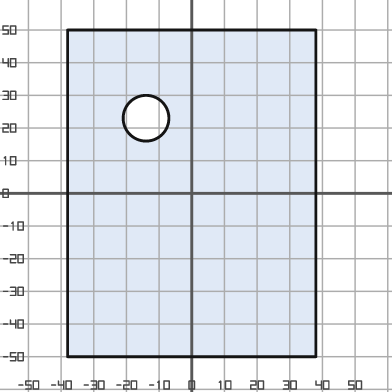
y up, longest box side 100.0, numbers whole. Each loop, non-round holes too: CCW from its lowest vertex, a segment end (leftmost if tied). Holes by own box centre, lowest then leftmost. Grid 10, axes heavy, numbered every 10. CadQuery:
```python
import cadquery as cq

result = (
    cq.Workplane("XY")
    .moveTo(-38.0, -50.0)
    .lineTo(38.0, -50.0)
    .lineTo(38.0, 50.0)
    .lineTo(-38.0, 50.0)
    .close()
    .moveTo(-14.0, 23.0)
    .circle(7.0)
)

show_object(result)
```